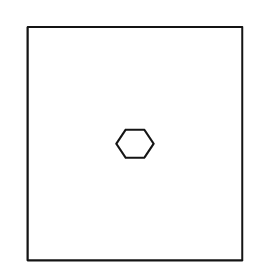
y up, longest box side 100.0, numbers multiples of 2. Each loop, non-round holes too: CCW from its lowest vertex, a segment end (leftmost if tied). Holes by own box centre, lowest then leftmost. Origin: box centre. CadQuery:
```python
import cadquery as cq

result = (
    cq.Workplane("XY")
    .moveTo(-46.0, -50.0)
    .lineTo(46.0, -50.0)
    .lineTo(46.0, 50.0)
    .lineTo(-46.0, 50.0)
    .close()
    .moveTo(-4.0, -6.0)
    .lineTo(4.0, -6.0)
    .lineTo(8.0, 0.0)
    .lineTo(4.0, 6.0)
    .lineTo(-4.0, 6.0)
    .lineTo(-8.0, 0.0)
    .close()
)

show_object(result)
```